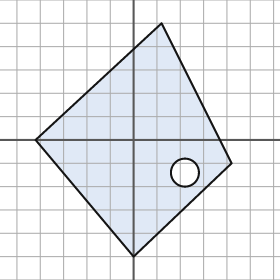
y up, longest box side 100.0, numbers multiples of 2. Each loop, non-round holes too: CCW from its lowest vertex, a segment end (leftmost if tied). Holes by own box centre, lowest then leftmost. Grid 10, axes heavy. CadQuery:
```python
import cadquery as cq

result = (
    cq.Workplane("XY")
    .moveTo(0.0, -50.0)
    .lineTo(42.0, -10.0)
    .lineTo(12.0, 50.0)
    .lineTo(-42.0, 0.0)
    .close()
    .moveTo(22.0, -14.0)
    .circle(6.0)
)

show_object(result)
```